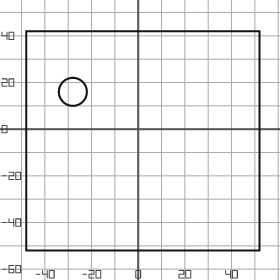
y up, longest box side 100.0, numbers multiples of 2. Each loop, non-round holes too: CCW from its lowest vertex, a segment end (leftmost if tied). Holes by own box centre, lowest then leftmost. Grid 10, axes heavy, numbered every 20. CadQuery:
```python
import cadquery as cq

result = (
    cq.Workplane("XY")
    .moveTo(-48.0, -52.0)
    .lineTo(52.0, -52.0)
    .lineTo(52.0, 42.0)
    .lineTo(-48.0, 42.0)
    .close()
    .moveTo(-28.0, 16.0)
    .circle(6.0)
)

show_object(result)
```